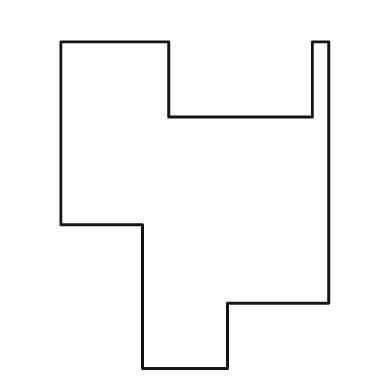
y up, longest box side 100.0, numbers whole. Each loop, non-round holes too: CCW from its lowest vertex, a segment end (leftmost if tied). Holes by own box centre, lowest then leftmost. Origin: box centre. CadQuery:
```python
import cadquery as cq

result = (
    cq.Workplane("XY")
    .moveTo(-16.0, -50.0)
    .lineTo(10.0, -50.0)
    .lineTo(10.0, -30.0)
    .lineTo(41.0, -30.0)
    .lineTo(41.0, 50.0)
    .lineTo(36.0, 50.0)
    .lineTo(36.0, 27.0)
    .lineTo(-8.0, 27.0)
    .lineTo(-8.0, 50.0)
    .lineTo(-41.0, 50.0)
    .lineTo(-41.0, -6.0)
    .lineTo(-16.0, -6.0)
    .close()
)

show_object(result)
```